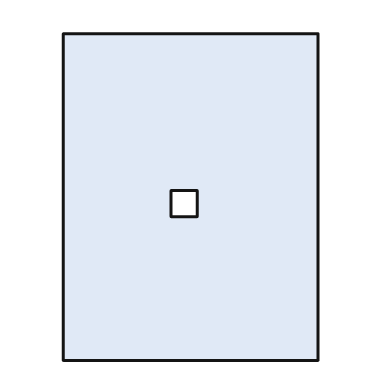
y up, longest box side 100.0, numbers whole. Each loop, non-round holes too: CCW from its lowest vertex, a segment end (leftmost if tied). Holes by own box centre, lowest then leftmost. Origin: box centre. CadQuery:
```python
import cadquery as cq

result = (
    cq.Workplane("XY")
    .moveTo(-39.0, -50.0)
    .lineTo(39.0, -50.0)
    .lineTo(39.0, 50.0)
    .lineTo(-39.0, 50.0)
    .close()
    .moveTo(-6.0, -6.0)
    .lineTo(2.0, -6.0)
    .lineTo(2.0, 2.0)
    .lineTo(-6.0, 2.0)
    .close()
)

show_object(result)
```